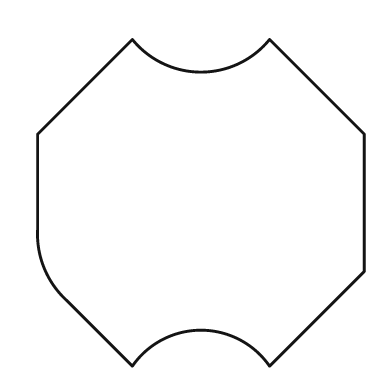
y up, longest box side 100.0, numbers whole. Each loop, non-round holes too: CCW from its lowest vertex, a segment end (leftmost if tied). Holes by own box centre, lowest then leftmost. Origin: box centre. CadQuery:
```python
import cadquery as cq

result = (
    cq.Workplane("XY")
    .moveTo(-21.0, -50.0)
    .threePointArc((0.0, -39.0), (21.0, -50.0))
    .lineTo(50.0, -21.0)
    .lineTo(50.0, 21.0)
    .lineTo(21.0, 50.0)
    .threePointArc((0.0, 40.0), (-21.0, 50.0))
    .lineTo(-50.0, 21.0)
    .lineTo(-50.0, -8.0)
    .threePointArc((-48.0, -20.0), (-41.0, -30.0))
    .close()
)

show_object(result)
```